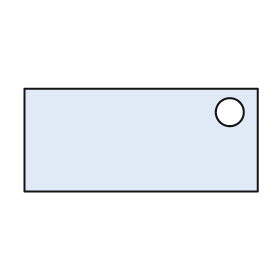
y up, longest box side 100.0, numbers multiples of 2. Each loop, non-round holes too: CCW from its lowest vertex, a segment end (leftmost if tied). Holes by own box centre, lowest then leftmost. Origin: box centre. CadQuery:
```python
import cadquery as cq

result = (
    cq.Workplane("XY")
    .moveTo(-50.0, -22.0)
    .lineTo(50.0, -22.0)
    .lineTo(50.0, 22.0)
    .lineTo(-50.0, 22.0)
    .close()
    .moveTo(38.0, 12.0)
    .circle(6.0)
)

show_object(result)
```